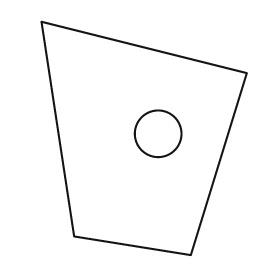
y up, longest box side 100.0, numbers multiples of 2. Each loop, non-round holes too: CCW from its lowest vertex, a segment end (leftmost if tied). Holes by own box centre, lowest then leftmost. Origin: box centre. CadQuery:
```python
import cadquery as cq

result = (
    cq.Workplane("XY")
    .moveTo(20.0, -50.0)
    .lineTo(44.0, 28.0)
    .lineTo(-44.0, 50.0)
    .lineTo(-30.0, -42.0)
    .close()
    .moveTo(6.0, 2.0)
    .circle(10.0)
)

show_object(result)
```